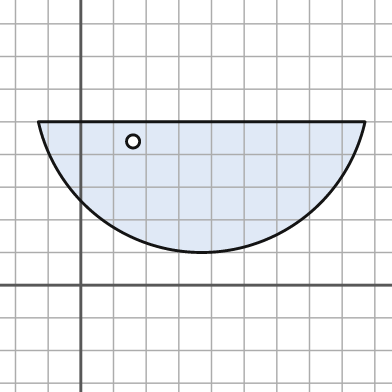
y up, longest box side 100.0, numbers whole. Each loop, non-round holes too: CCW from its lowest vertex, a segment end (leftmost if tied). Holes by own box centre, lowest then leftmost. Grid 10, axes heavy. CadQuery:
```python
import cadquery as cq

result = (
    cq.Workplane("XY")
    .moveTo(-13.0, 50.0)
    .threePointArc((37.0, 10.0), (87.0, 50.0))
    .close()
    .moveTo(16.0, 44.0)
    .circle(2.0)
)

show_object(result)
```